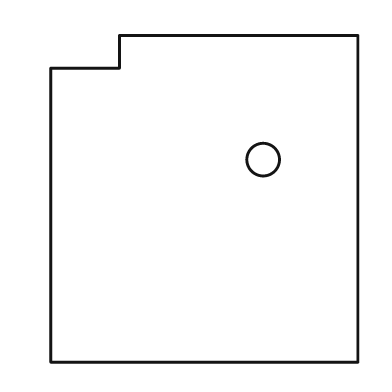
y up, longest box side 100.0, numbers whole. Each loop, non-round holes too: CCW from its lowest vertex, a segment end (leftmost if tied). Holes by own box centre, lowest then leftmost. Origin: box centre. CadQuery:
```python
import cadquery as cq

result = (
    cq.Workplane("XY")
    .moveTo(-47.0, -50.0)
    .lineTo(47.0, -50.0)
    .lineTo(47.0, 50.0)
    .lineTo(-26.0, 50.0)
    .lineTo(-26.0, 40.0)
    .lineTo(-47.0, 40.0)
    .close()
    .moveTo(18.0, 12.0)
    .circle(5.0)
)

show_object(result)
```